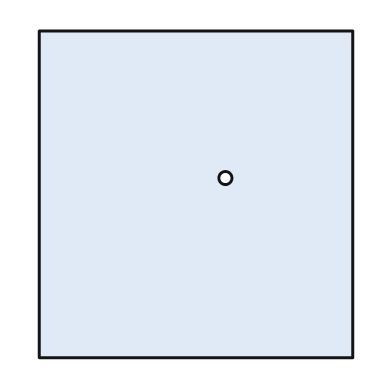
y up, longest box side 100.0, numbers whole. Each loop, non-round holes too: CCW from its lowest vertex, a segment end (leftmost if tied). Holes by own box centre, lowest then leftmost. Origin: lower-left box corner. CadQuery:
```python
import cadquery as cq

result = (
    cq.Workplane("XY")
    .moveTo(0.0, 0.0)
    .lineTo(96.0, 0.0)
    .lineTo(96.0, 100.0)
    .lineTo(0.0, 100.0)
    .close()
    .moveTo(57.0, 55.0)
    .circle(2.0)
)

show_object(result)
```